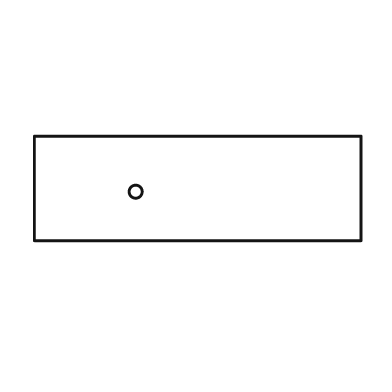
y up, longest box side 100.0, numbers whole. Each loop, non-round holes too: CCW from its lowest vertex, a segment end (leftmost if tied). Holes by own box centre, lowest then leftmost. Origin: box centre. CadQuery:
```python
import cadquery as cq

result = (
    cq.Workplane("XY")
    .moveTo(-50.0, -16.0)
    .lineTo(50.0, -16.0)
    .lineTo(50.0, 16.0)
    .lineTo(-50.0, 16.0)
    .close()
    .moveTo(-19.0, -1.0)
    .circle(2.0)
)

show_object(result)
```